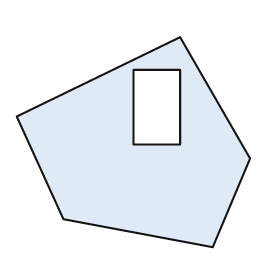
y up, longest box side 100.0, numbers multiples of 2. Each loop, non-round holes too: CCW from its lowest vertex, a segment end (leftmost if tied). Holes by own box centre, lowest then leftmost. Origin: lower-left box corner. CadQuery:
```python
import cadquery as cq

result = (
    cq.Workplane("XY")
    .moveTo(84.0, 0.0)
    .lineTo(100.0, 38.0)
    .lineTo(70.0, 90.0)
    .lineTo(0.0, 56.0)
    .lineTo(20.0, 12.0)
    .close()
    .moveTo(50.0, 44.0)
    .lineTo(70.0, 44.0)
    .lineTo(70.0, 76.0)
    .lineTo(50.0, 76.0)
    .close()
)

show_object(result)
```